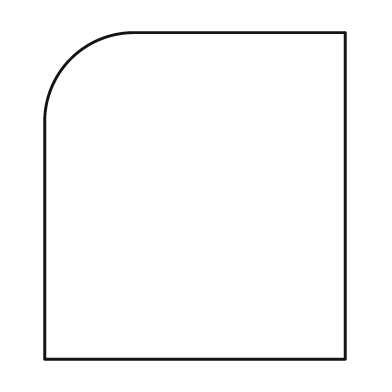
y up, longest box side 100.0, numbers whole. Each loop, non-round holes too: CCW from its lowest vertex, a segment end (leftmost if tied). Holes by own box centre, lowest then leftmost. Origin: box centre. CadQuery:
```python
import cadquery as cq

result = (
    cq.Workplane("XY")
    .moveTo(-46.0, -50.0)
    .lineTo(46.0, -50.0)
    .lineTo(46.0, 50.0)
    .lineTo(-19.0, 50.0)
    .threePointArc((-38.0, 42.0), (-46.0, 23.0))
    .close()
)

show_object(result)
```